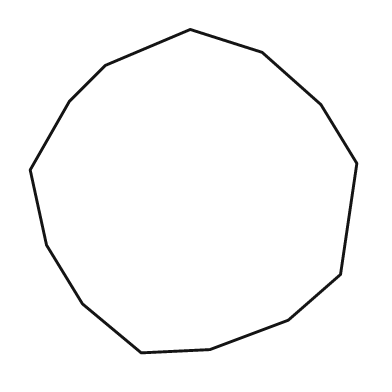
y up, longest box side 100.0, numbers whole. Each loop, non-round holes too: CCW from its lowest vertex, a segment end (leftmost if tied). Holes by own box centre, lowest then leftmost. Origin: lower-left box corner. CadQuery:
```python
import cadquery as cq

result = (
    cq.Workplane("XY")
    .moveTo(34.0, 0.0)
    .lineTo(55.0, 1.0)
    .lineTo(79.0, 10.0)
    .lineTo(95.0, 24.0)
    .lineTo(100.0, 58.0)
    .lineTo(89.0, 76.0)
    .lineTo(71.0, 92.0)
    .lineTo(49.0, 99.0)
    .lineTo(23.0, 88.0)
    .lineTo(12.0, 77.0)
    .lineTo(0.0, 56.0)
    .lineTo(5.0, 33.0)
    .lineTo(16.0, 15.0)
    .close()
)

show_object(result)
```